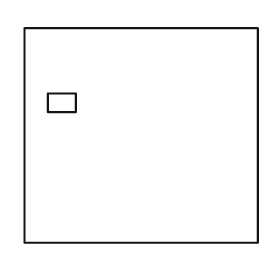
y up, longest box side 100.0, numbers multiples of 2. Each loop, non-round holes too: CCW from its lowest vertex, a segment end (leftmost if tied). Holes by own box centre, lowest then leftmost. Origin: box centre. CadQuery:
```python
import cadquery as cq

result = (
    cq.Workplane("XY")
    .moveTo(-50.0, -46.0)
    .lineTo(50.0, -46.0)
    .lineTo(50.0, 46.0)
    .lineTo(-50.0, 46.0)
    .close()
    .moveTo(-40.0, 10.0)
    .lineTo(-28.0, 10.0)
    .lineTo(-28.0, 18.0)
    .lineTo(-40.0, 18.0)
    .close()
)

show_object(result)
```